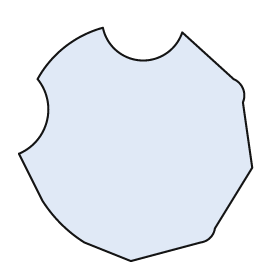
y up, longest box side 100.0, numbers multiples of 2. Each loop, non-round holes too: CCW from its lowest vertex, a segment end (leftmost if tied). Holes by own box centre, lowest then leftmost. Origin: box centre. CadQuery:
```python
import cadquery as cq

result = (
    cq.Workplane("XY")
    .moveTo(-2.0, -50.0)
    .lineTo(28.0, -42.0)
    .threePointArc((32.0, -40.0), (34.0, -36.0))
    .lineTo(50.0, -10.0)
    .lineTo(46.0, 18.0)
    .threePointArc((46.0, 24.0), (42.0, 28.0))
    .lineTo(20.0, 48.0)
    .threePointArc((2.0, 36.0), (-14.0, 50.0))
    .threePointArc((-30.0, 42.0), (-42.0, 28.0))
    .threePointArc((-38.0, 10.0), (-50.0, -4.0))
    .lineTo(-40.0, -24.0)
    .threePointArc((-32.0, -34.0), (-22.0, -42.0))
    .close()
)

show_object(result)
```